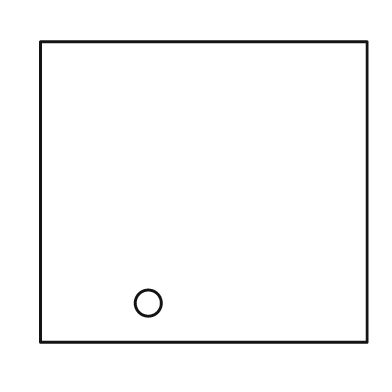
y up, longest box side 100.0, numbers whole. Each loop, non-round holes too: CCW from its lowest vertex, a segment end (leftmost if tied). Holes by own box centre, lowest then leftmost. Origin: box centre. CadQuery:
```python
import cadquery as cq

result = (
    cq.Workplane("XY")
    .moveTo(-50.0, -46.0)
    .lineTo(50.0, -46.0)
    .lineTo(50.0, 46.0)
    .lineTo(-50.0, 46.0)
    .close()
    .moveTo(-17.0, -34.0)
    .circle(4.0)
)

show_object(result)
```